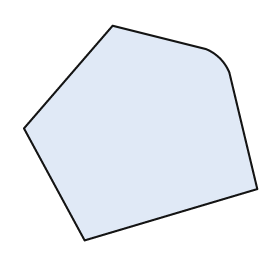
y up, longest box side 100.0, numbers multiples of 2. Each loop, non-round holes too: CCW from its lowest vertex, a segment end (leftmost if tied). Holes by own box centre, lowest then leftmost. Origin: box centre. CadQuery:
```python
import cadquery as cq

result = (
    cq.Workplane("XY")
    .moveTo(-24.0, -46.0)
    .lineTo(50.0, -24.0)
    .lineTo(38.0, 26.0)
    .threePointArc((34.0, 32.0), (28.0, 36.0))
    .lineTo(-12.0, 46.0)
    .lineTo(-50.0, 2.0)
    .close()
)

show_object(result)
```